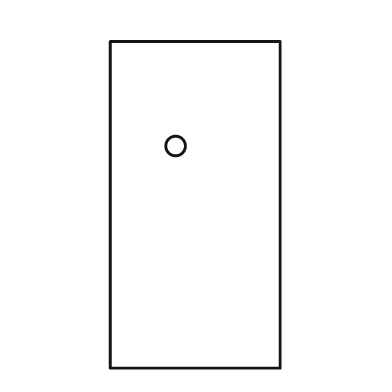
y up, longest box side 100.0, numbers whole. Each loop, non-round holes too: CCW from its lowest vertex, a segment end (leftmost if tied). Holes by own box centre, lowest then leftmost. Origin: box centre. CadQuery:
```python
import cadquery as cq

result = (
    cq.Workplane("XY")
    .moveTo(-26.0, -50.0)
    .lineTo(26.0, -50.0)
    .lineTo(26.0, 50.0)
    .lineTo(-26.0, 50.0)
    .close()
    .moveTo(-6.0, 18.0)
    .circle(3.0)
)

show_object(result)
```